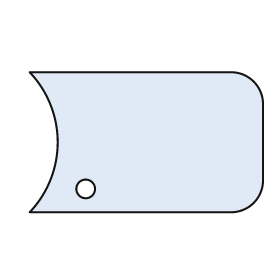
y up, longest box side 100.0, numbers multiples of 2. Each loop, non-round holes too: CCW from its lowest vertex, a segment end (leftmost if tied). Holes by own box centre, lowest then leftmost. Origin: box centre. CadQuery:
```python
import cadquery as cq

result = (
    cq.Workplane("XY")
    .moveTo(-50.0, -30.0)
    .lineTo(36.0, -30.0)
    .threePointArc((46.0, -26.0), (50.0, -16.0))
    .lineTo(50.0, 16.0)
    .threePointArc((46.0, 26.0), (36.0, 30.0))
    .lineTo(-50.0, 30.0)
    .threePointArc((-38.0, 0.0), (-50.0, -30.0))
    .close()
    .moveTo(-26.0, -20.0)
    .circle(4.0)
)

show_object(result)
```